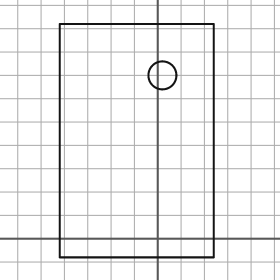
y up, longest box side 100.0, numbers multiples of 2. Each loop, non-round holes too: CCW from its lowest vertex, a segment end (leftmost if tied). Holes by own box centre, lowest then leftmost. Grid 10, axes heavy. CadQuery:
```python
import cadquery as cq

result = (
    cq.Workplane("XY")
    .moveTo(-42.0, -8.0)
    .lineTo(24.0, -8.0)
    .lineTo(24.0, 92.0)
    .lineTo(-42.0, 92.0)
    .close()
    .moveTo(2.0, 70.0)
    .circle(6.0)
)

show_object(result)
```